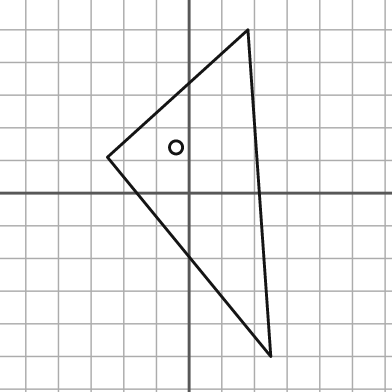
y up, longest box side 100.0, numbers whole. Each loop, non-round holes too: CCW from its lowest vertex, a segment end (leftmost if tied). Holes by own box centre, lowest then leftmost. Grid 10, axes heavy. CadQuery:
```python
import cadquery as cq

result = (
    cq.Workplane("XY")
    .moveTo(25.0, -50.0)
    .lineTo(18.0, 50.0)
    .lineTo(-25.0, 11.0)
    .close()
    .moveTo(-4.0, 14.0)
    .circle(2.0)
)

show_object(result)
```